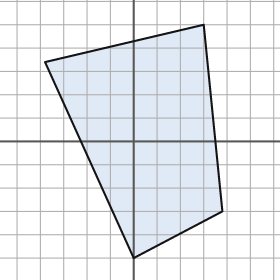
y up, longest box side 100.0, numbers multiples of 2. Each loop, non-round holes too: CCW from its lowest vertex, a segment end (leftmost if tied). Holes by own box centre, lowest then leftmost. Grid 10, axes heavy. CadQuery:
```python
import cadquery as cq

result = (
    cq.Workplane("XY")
    .moveTo(0.0, -50.0)
    .lineTo(38.0, -30.0)
    .lineTo(30.0, 50.0)
    .lineTo(-38.0, 34.0)
    .close()
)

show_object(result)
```